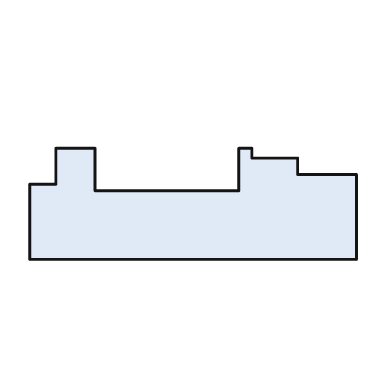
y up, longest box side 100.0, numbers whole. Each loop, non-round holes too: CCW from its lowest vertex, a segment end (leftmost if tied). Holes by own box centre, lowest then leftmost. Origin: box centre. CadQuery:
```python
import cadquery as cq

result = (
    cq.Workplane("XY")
    .moveTo(-50.0, -17.0)
    .lineTo(50.0, -17.0)
    .lineTo(50.0, 9.0)
    .lineTo(32.0, 9.0)
    .lineTo(32.0, 14.0)
    .lineTo(18.0, 14.0)
    .lineTo(18.0, 17.0)
    .lineTo(14.0, 17.0)
    .lineTo(14.0, 4.0)
    .lineTo(-30.0, 4.0)
    .lineTo(-30.0, 17.0)
    .lineTo(-42.0, 17.0)
    .lineTo(-42.0, 6.0)
    .lineTo(-50.0, 6.0)
    .close()
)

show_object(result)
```